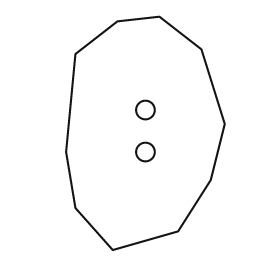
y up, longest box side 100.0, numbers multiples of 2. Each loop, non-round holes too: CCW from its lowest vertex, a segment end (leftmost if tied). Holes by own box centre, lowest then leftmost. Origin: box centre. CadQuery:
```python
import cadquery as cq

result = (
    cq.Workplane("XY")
    .moveTo(-14.0, -50.0)
    .lineTo(14.0, -42.0)
    .lineTo(28.0, -20.0)
    .lineTo(34.0, 4.0)
    .lineTo(24.0, 36.0)
    .lineTo(6.0, 50.0)
    .lineTo(-12.0, 48.0)
    .lineTo(-30.0, 34.0)
    .lineTo(-34.0, -8.0)
    .lineTo(-30.0, -32.0)
    .close()
    .moveTo(0.0, -8.0)
    .circle(4.0)
    .moveTo(0.0, 10.0)
    .circle(4.0)
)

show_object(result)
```